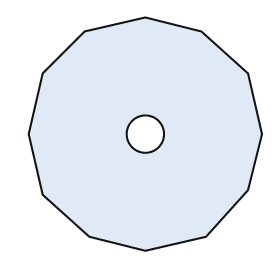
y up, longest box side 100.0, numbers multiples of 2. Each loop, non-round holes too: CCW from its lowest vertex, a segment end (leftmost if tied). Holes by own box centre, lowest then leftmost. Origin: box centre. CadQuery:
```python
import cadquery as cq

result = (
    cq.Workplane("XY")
    .moveTo(0.0, -50.0)
    .lineTo(26.0, -44.0)
    .lineTo(44.0, -24.0)
    .lineTo(50.0, 0.0)
    .lineTo(44.0, 26.0)
    .lineTo(24.0, 44.0)
    .lineTo(0.0, 50.0)
    .lineTo(-26.0, 44.0)
    .lineTo(-44.0, 26.0)
    .lineTo(-50.0, 0.0)
    .lineTo(-44.0, -26.0)
    .lineTo(-24.0, -44.0)
    .close()
    .moveTo(0.0, 0.0)
    .circle(8.0)
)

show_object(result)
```